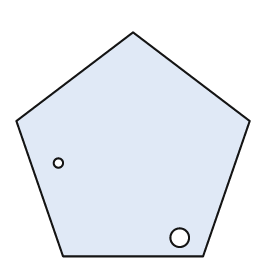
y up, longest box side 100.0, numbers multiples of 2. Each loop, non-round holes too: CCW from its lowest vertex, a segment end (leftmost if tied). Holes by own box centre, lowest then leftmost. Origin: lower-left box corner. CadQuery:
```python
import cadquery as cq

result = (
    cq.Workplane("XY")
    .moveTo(20.0, 0.0)
    .lineTo(80.0, 0.0)
    .lineTo(100.0, 58.0)
    .lineTo(50.0, 96.0)
    .lineTo(0.0, 58.0)
    .close()
    .moveTo(70.0, 8.0)
    .circle(4.0)
    .moveTo(18.0, 40.0)
    .circle(2.0)
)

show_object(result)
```